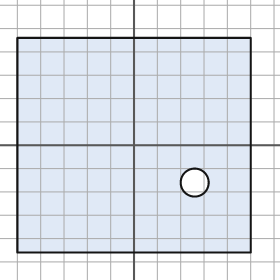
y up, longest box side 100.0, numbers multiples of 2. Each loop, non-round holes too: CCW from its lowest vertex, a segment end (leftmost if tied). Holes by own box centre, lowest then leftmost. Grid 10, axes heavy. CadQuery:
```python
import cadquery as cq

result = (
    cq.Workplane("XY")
    .moveTo(-50.0, -46.0)
    .lineTo(50.0, -46.0)
    .lineTo(50.0, 46.0)
    .lineTo(-50.0, 46.0)
    .close()
    .moveTo(26.0, -16.0)
    .circle(6.0)
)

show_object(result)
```